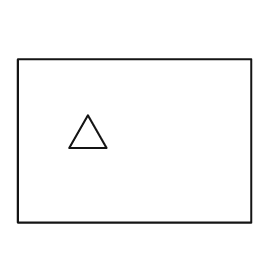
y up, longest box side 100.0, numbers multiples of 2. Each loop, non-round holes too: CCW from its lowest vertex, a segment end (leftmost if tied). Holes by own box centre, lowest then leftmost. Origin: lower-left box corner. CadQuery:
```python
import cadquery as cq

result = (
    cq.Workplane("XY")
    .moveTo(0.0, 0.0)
    .lineTo(100.0, 0.0)
    .lineTo(100.0, 70.0)
    .lineTo(0.0, 70.0)
    .close()
    .moveTo(22.0, 32.0)
    .lineTo(38.0, 32.0)
    .lineTo(30.0, 46.0)
    .close()
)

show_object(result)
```